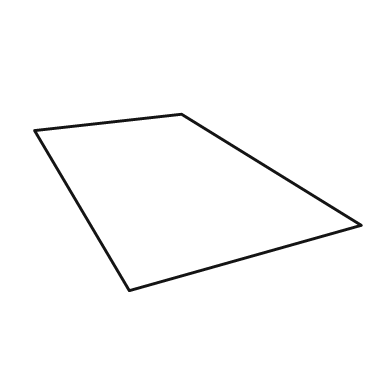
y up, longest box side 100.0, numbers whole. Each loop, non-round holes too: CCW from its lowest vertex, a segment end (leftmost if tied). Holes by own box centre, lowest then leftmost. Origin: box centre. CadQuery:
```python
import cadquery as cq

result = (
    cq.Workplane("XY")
    .moveTo(-21.0, -27.0)
    .lineTo(50.0, -7.0)
    .lineTo(-5.0, 27.0)
    .lineTo(-50.0, 22.0)
    .close()
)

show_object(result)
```